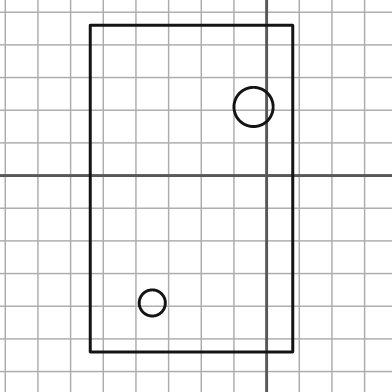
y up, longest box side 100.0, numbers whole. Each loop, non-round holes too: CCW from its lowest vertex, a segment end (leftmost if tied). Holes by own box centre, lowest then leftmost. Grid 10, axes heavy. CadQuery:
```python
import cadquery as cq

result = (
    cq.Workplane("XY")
    .moveTo(-54.0, -54.0)
    .lineTo(8.0, -54.0)
    .lineTo(8.0, 46.0)
    .lineTo(-54.0, 46.0)
    .close()
    .moveTo(-35.0, -39.0)
    .circle(4.0)
    .moveTo(-4.0, 21.0)
    .circle(6.0)
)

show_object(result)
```